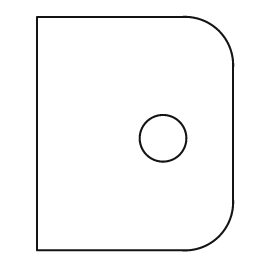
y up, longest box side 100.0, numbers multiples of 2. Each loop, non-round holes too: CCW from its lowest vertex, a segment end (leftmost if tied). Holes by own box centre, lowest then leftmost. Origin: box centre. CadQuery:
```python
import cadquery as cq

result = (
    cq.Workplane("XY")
    .moveTo(-42.0, -50.0)
    .lineTo(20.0, -50.0)
    .threePointArc((36.0, -44.0), (42.0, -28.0))
    .lineTo(42.0, 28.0)
    .threePointArc((36.0, 44.0), (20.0, 50.0))
    .lineTo(-42.0, 50.0)
    .close()
    .moveTo(12.0, -2.0)
    .circle(10.0)
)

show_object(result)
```